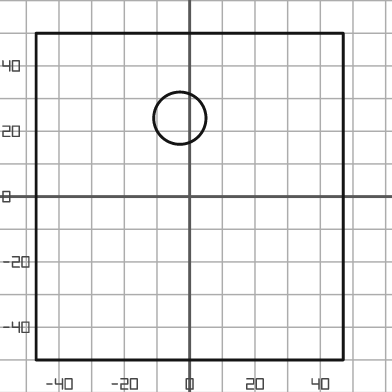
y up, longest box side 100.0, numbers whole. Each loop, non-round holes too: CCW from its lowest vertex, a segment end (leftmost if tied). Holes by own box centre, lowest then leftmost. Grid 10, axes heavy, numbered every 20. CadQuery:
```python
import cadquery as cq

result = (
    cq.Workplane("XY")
    .moveTo(-47.0, -50.0)
    .lineTo(47.0, -50.0)
    .lineTo(47.0, 50.0)
    .lineTo(-47.0, 50.0)
    .close()
    .moveTo(-3.0, 24.0)
    .circle(8.0)
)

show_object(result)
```